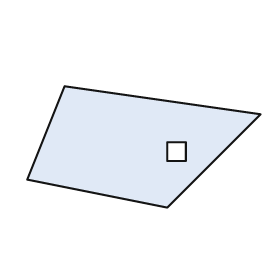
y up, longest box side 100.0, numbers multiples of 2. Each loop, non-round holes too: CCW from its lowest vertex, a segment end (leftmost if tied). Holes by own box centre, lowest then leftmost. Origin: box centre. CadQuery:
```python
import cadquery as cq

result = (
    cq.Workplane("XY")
    .moveTo(10.0, -26.0)
    .lineTo(50.0, 14.0)
    .lineTo(-34.0, 26.0)
    .lineTo(-50.0, -14.0)
    .close()
    .moveTo(10.0, -6.0)
    .lineTo(18.0, -6.0)
    .lineTo(18.0, 2.0)
    .lineTo(10.0, 2.0)
    .close()
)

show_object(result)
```